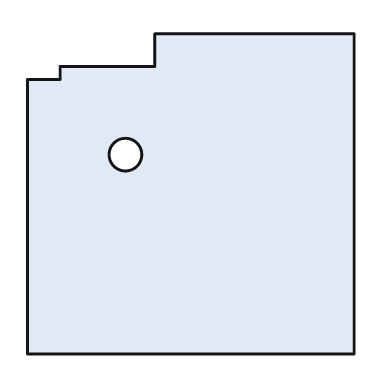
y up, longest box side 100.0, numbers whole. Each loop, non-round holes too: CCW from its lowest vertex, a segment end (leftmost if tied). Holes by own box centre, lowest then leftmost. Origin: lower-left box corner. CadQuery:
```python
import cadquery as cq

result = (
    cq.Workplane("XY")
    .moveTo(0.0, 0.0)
    .lineTo(100.0, 0.0)
    .lineTo(100.0, 98.0)
    .lineTo(39.0, 98.0)
    .lineTo(39.0, 88.0)
    .lineTo(10.0, 88.0)
    .lineTo(10.0, 84.0)
    .lineTo(0.0, 84.0)
    .close()
    .moveTo(30.0, 61.0)
    .circle(5.0)
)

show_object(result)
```